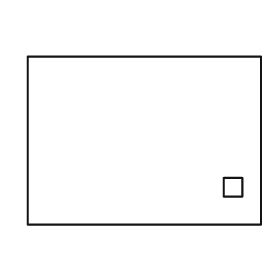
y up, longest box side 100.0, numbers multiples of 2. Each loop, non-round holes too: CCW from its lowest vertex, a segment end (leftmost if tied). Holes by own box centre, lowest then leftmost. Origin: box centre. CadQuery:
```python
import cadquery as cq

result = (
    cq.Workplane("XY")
    .moveTo(-50.0, -36.0)
    .lineTo(50.0, -36.0)
    .lineTo(50.0, 36.0)
    .lineTo(-50.0, 36.0)
    .close()
    .moveTo(34.0, -24.0)
    .lineTo(42.0, -24.0)
    .lineTo(42.0, -16.0)
    .lineTo(34.0, -16.0)
    .close()
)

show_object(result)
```